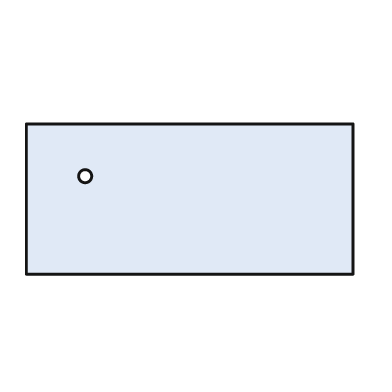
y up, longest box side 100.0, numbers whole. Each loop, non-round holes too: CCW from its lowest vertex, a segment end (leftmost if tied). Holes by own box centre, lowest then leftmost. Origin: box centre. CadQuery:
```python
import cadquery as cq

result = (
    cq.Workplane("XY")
    .moveTo(-50.0, -23.0)
    .lineTo(50.0, -23.0)
    .lineTo(50.0, 23.0)
    .lineTo(-50.0, 23.0)
    .close()
    .moveTo(-32.0, 7.0)
    .circle(2.0)
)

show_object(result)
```